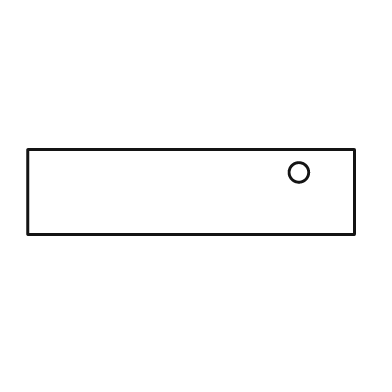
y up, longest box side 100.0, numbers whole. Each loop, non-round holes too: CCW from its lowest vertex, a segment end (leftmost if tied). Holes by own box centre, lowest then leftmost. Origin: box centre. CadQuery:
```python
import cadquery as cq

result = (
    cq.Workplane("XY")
    .moveTo(-50.0, -13.0)
    .lineTo(50.0, -13.0)
    .lineTo(50.0, 13.0)
    .lineTo(-50.0, 13.0)
    .close()
    .moveTo(33.0, 6.0)
    .circle(3.0)
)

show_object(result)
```